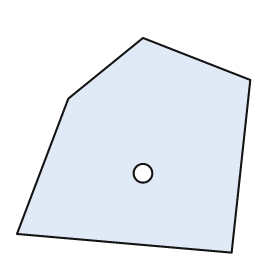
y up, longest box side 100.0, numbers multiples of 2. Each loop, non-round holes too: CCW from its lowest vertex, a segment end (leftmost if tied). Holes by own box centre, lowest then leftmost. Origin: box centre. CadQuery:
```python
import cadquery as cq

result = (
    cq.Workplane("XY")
    .moveTo(42.0, -46.0)
    .lineTo(50.0, 28.0)
    .lineTo(4.0, 46.0)
    .lineTo(-28.0, 20.0)
    .lineTo(-50.0, -38.0)
    .close()
    .moveTo(4.0, -12.0)
    .circle(4.0)
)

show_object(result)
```